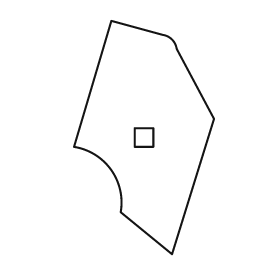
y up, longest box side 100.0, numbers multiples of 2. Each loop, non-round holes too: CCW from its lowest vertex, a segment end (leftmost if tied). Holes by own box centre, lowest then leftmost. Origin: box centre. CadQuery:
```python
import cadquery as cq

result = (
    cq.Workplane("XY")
    .moveTo(12.0, -50.0)
    .lineTo(30.0, 8.0)
    .lineTo(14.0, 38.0)
    .threePointArc((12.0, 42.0), (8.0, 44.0))
    .lineTo(-14.0, 50.0)
    .lineTo(-30.0, -4.0)
    .threePointArc((-14.0, -14.0), (-10.0, -32.0))
    .close()
    .moveTo(-4.0, -4.0)
    .lineTo(4.0, -4.0)
    .lineTo(4.0, 4.0)
    .lineTo(-4.0, 4.0)
    .close()
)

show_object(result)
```